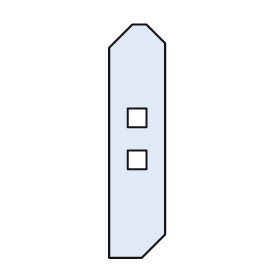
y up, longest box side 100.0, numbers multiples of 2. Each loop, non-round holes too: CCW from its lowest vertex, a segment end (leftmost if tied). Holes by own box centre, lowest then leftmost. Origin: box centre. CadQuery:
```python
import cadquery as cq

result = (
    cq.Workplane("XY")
    .moveTo(-12.0, -50.0)
    .lineTo(2.0, -50.0)
    .lineTo(12.0, -40.0)
    .lineTo(12.0, 42.0)
    .lineTo(4.0, 50.0)
    .lineTo(-2.0, 50.0)
    .lineTo(-12.0, 40.0)
    .close()
    .moveTo(-4.0, -12.0)
    .lineTo(4.0, -12.0)
    .lineTo(4.0, -4.0)
    .lineTo(-4.0, -4.0)
    .close()
    .moveTo(-4.0, 6.0)
    .lineTo(4.0, 6.0)
    .lineTo(4.0, 14.0)
    .lineTo(-4.0, 14.0)
    .close()
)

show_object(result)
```